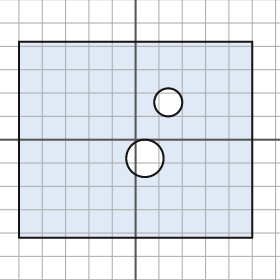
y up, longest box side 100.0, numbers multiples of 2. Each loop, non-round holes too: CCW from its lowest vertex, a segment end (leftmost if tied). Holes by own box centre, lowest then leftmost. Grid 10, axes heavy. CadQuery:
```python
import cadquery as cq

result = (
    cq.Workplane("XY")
    .moveTo(-50.0, -42.0)
    .lineTo(50.0, -42.0)
    .lineTo(50.0, 42.0)
    .lineTo(-50.0, 42.0)
    .close()
    .moveTo(4.0, -8.0)
    .circle(8.0)
    .moveTo(14.0, 16.0)
    .circle(6.0)
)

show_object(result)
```